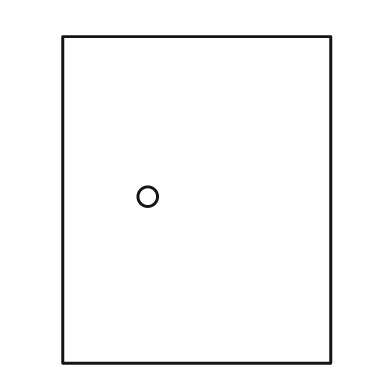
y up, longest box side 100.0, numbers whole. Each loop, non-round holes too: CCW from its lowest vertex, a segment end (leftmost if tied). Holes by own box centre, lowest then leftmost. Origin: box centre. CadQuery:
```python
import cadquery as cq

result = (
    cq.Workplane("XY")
    .moveTo(-41.0, -50.0)
    .lineTo(41.0, -50.0)
    .lineTo(41.0, 50.0)
    .lineTo(-41.0, 50.0)
    .close()
    .moveTo(-15.0, 1.0)
    .circle(3.0)
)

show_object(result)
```